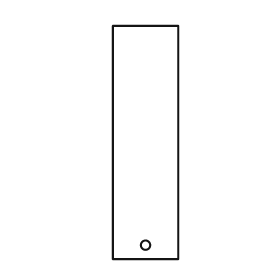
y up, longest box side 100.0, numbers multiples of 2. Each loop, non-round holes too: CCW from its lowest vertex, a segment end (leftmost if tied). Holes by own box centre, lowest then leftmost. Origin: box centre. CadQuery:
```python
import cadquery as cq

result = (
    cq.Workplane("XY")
    .moveTo(-14.0, -50.0)
    .lineTo(14.0, -50.0)
    .lineTo(14.0, 50.0)
    .lineTo(-14.0, 50.0)
    .close()
    .moveTo(0.0, -44.0)
    .circle(2.0)
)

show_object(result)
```